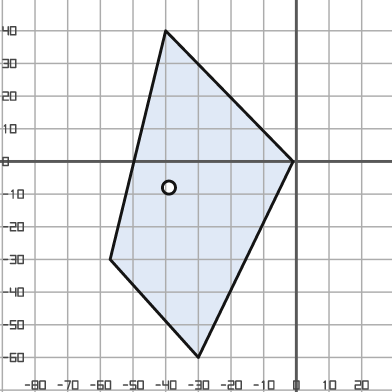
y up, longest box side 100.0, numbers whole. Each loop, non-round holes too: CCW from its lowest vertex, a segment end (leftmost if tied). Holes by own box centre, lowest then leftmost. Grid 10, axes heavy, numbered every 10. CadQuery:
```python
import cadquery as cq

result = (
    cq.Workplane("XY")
    .moveTo(-30.0, -60.0)
    .lineTo(-1.0, 0.0)
    .lineTo(-40.0, 40.0)
    .lineTo(-57.0, -30.0)
    .close()
    .moveTo(-39.0, -8.0)
    .circle(2.0)
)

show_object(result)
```